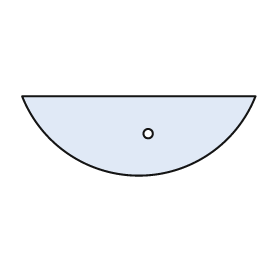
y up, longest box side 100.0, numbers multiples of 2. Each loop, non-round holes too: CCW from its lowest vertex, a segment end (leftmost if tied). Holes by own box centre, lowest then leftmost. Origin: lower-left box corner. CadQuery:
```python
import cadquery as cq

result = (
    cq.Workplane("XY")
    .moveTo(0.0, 34.0)
    .threePointArc((50.0, 0.0), (100.0, 34.0))
    .close()
    .moveTo(54.0, 18.0)
    .circle(2.0)
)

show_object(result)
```